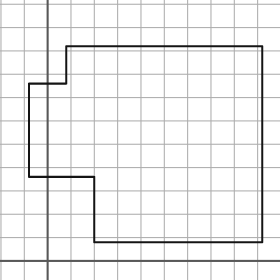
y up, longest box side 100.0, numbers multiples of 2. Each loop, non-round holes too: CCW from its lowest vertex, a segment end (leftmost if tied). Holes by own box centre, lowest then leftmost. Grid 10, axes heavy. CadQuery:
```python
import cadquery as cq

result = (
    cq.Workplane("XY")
    .moveTo(20.0, 8.0)
    .lineTo(92.0, 8.0)
    .lineTo(92.0, 92.0)
    .lineTo(8.0, 92.0)
    .lineTo(8.0, 76.0)
    .lineTo(-8.0, 76.0)
    .lineTo(-8.0, 36.0)
    .lineTo(20.0, 36.0)
    .close()
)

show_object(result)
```